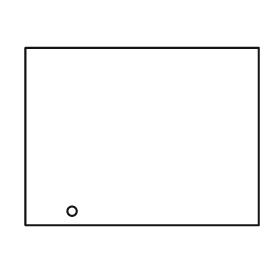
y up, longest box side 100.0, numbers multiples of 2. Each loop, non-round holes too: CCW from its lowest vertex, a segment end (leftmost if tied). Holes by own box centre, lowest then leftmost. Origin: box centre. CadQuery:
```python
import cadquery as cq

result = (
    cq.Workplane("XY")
    .moveTo(-50.0, -38.0)
    .lineTo(50.0, -38.0)
    .lineTo(50.0, 38.0)
    .lineTo(-50.0, 38.0)
    .close()
    .moveTo(-30.0, -32.0)
    .circle(2.0)
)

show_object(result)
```